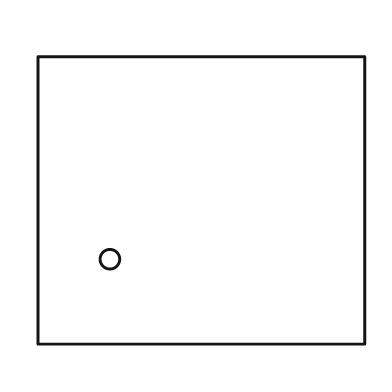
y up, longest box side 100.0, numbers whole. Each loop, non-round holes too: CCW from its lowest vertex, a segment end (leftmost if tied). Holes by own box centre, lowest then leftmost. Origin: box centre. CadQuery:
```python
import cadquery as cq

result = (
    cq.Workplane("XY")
    .moveTo(-50.0, -44.0)
    .lineTo(50.0, -44.0)
    .lineTo(50.0, 44.0)
    .lineTo(-50.0, 44.0)
    .close()
    .moveTo(-28.0, -18.0)
    .circle(3.0)
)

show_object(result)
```